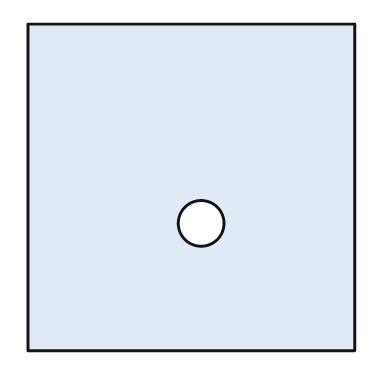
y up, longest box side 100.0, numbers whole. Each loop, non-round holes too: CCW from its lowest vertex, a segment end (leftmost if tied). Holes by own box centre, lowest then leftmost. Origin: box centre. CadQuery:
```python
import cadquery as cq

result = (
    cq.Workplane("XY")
    .moveTo(-50.0, -50.0)
    .lineTo(50.0, -50.0)
    .lineTo(50.0, 50.0)
    .lineTo(-50.0, 50.0)
    .close()
    .moveTo(3.0, -11.0)
    .circle(7.0)
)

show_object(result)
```